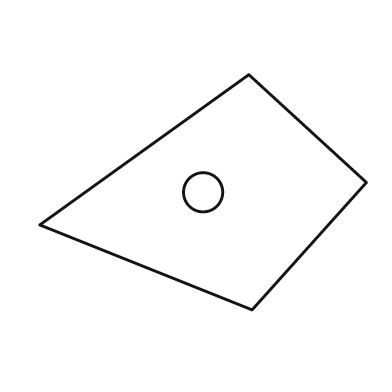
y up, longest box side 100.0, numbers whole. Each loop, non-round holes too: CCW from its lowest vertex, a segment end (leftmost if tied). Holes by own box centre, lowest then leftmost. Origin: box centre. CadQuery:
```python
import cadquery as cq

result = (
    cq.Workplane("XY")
    .moveTo(15.0, -36.0)
    .lineTo(50.0, 3.0)
    .lineTo(14.0, 36.0)
    .lineTo(-50.0, -10.0)
    .close()
    .moveTo(0.0, 0.0)
    .circle(6.0)
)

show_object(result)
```